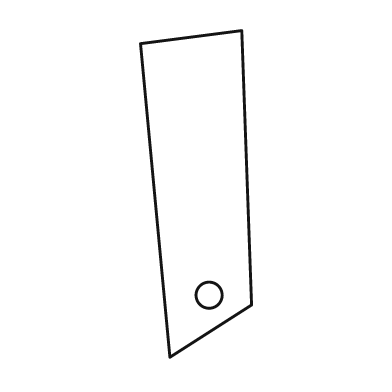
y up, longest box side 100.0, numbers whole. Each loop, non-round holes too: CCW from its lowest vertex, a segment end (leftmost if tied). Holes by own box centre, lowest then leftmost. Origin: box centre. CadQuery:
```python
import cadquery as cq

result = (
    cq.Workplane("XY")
    .moveTo(-8.0, -50.0)
    .lineTo(17.0, -34.0)
    .lineTo(14.0, 50.0)
    .lineTo(-17.0, 46.0)
    .close()
    .moveTo(4.0, -31.0)
    .circle(4.0)
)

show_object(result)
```